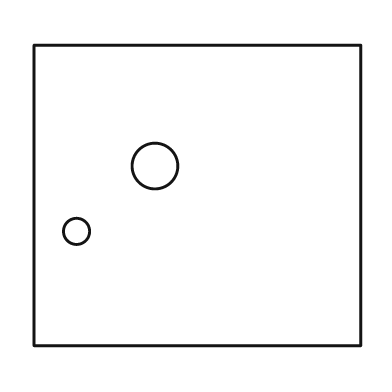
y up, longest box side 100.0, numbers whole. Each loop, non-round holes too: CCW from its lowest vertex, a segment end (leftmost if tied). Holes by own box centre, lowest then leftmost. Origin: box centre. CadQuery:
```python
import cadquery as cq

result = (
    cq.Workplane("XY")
    .moveTo(-50.0, -46.0)
    .lineTo(50.0, -46.0)
    .lineTo(50.0, 46.0)
    .lineTo(-50.0, 46.0)
    .close()
    .moveTo(-37.0, -11.0)
    .circle(4.0)
    .moveTo(-13.0, 9.0)
    .circle(7.0)
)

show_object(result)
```